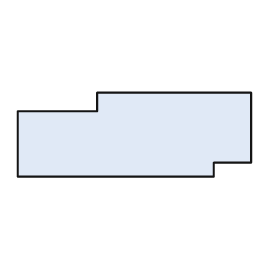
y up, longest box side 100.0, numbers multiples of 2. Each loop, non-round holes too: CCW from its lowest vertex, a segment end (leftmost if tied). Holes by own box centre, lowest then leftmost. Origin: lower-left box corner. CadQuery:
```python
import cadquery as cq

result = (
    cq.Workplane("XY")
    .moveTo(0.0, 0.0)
    .lineTo(84.0, 0.0)
    .lineTo(84.0, 6.0)
    .lineTo(100.0, 6.0)
    .lineTo(100.0, 36.0)
    .lineTo(34.0, 36.0)
    .lineTo(34.0, 28.0)
    .lineTo(0.0, 28.0)
    .close()
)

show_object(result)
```